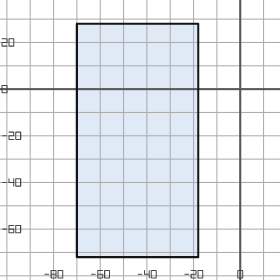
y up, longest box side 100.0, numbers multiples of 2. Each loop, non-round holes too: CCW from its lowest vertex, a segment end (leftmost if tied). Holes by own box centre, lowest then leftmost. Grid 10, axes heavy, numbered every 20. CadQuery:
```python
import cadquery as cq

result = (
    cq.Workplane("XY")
    .moveTo(-70.0, -72.0)
    .lineTo(-18.0, -72.0)
    .lineTo(-18.0, 28.0)
    .lineTo(-70.0, 28.0)
    .close()
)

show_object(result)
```